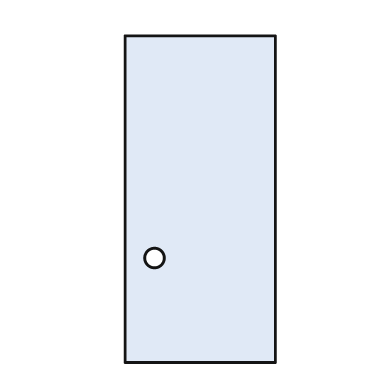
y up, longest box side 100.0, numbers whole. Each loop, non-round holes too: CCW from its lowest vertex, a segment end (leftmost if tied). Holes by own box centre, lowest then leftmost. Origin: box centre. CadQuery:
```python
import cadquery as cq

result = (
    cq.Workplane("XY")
    .moveTo(-23.0, -50.0)
    .lineTo(23.0, -50.0)
    .lineTo(23.0, 50.0)
    .lineTo(-23.0, 50.0)
    .close()
    .moveTo(-14.0, -18.0)
    .circle(3.0)
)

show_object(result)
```